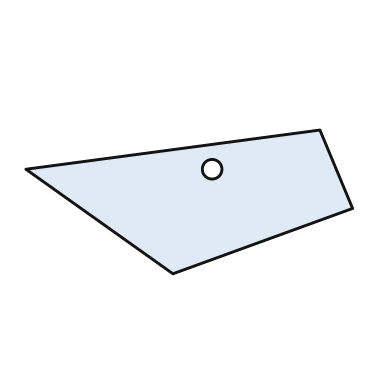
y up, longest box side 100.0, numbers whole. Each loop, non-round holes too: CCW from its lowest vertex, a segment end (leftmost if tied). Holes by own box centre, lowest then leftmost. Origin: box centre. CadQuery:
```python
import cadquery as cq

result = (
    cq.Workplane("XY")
    .moveTo(-5.0, -22.0)
    .lineTo(50.0, -2.0)
    .lineTo(40.0, 22.0)
    .lineTo(-50.0, 10.0)
    .close()
    .moveTo(7.0, 10.0)
    .circle(3.0)
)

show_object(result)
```